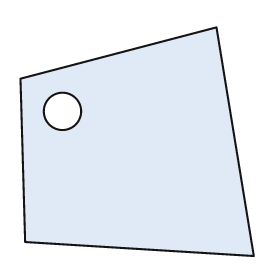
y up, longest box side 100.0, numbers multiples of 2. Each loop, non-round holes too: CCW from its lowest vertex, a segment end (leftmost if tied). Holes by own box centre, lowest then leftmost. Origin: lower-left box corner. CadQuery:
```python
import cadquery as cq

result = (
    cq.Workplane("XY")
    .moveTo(100.0, 0.0)
    .lineTo(84.0, 98.0)
    .lineTo(0.0, 76.0)
    .lineTo(2.0, 6.0)
    .close()
    .moveTo(18.0, 62.0)
    .circle(8.0)
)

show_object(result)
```